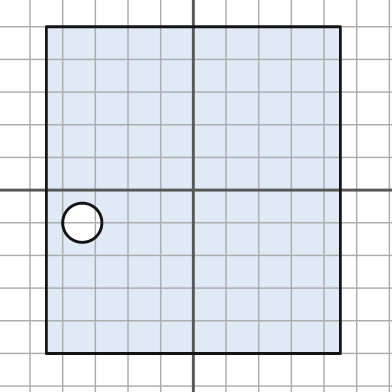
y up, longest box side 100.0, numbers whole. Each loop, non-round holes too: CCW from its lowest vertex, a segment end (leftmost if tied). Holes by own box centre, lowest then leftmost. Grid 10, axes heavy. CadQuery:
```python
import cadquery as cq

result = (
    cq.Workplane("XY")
    .moveTo(-45.0, -50.0)
    .lineTo(45.0, -50.0)
    .lineTo(45.0, 50.0)
    .lineTo(-45.0, 50.0)
    .close()
    .moveTo(-34.0, -10.0)
    .circle(6.0)
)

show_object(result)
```